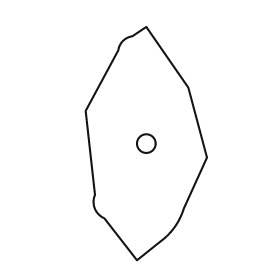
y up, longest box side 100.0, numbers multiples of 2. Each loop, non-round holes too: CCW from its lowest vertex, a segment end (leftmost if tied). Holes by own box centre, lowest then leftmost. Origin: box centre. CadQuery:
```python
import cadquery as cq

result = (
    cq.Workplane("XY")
    .moveTo(-4.0, -50.0)
    .lineTo(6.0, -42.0)
    .threePointArc((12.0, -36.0), (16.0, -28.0))
    .lineTo(26.0, -6.0)
    .lineTo(18.0, 24.0)
    .lineTo(0.0, 50.0)
    .lineTo(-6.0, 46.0)
    .threePointArc((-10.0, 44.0), (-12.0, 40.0))
    .lineTo(-26.0, 14.0)
    .lineTo(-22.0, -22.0)
    .threePointArc((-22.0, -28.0), (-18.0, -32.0))
    .close()
    .moveTo(0.0, 0.0)
    .circle(4.0)
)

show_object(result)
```